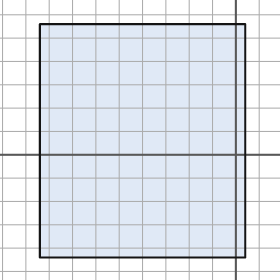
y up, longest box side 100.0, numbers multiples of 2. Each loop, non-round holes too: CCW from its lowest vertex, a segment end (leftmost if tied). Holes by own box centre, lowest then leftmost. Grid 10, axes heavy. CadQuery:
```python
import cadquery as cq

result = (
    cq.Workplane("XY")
    .moveTo(-84.0, -44.0)
    .lineTo(4.0, -44.0)
    .lineTo(4.0, 56.0)
    .lineTo(-84.0, 56.0)
    .close()
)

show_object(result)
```